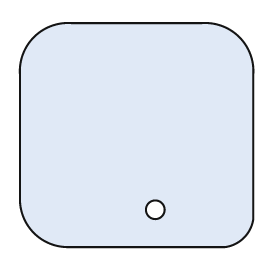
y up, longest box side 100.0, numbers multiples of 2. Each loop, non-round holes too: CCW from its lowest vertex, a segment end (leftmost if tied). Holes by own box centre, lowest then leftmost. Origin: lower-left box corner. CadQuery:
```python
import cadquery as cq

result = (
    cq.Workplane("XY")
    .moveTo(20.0, 0.0)
    .lineTo(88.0, 0.0)
    .threePointArc((96.0, 4.0), (100.0, 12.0))
    .lineTo(100.0, 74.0)
    .threePointArc((94.0, 90.0), (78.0, 96.0))
    .lineTo(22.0, 96.0)
    .threePointArc((6.0, 90.0), (0.0, 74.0))
    .lineTo(0.0, 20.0)
    .threePointArc((6.0, 6.0), (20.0, 0.0))
    .close()
    .moveTo(58.0, 16.0)
    .circle(4.0)
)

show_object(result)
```